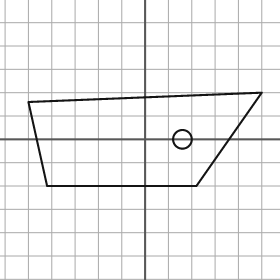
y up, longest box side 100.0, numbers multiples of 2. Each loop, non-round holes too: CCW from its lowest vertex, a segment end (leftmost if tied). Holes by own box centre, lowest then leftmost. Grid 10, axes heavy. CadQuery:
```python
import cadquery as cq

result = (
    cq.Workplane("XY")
    .moveTo(-42.0, -20.0)
    .lineTo(22.0, -20.0)
    .lineTo(50.0, 20.0)
    .lineTo(-50.0, 16.0)
    .close()
    .moveTo(16.0, 0.0)
    .circle(4.0)
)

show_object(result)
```